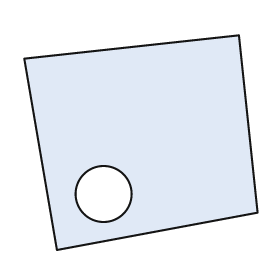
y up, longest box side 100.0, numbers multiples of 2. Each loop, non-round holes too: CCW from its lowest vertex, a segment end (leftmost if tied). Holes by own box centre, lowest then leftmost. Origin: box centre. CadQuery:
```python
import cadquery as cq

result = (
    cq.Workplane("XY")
    .moveTo(-36.0, -46.0)
    .lineTo(50.0, -30.0)
    .lineTo(42.0, 46.0)
    .lineTo(-50.0, 36.0)
    .close()
    .moveTo(-16.0, -22.0)
    .circle(12.0)
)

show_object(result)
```